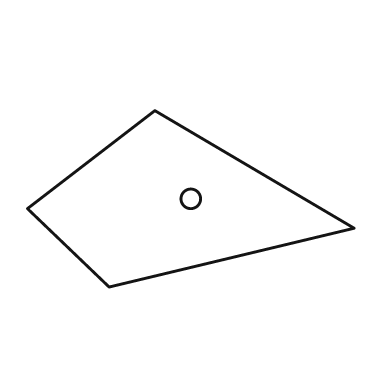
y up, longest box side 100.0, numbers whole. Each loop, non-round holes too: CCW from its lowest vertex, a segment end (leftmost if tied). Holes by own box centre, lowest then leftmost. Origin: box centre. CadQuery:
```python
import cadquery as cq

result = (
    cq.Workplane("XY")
    .moveTo(-25.0, -27.0)
    .lineTo(50.0, -9.0)
    .lineTo(-11.0, 27.0)
    .lineTo(-50.0, -3.0)
    .close()
    .moveTo(0.0, 0.0)
    .circle(3.0)
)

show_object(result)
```